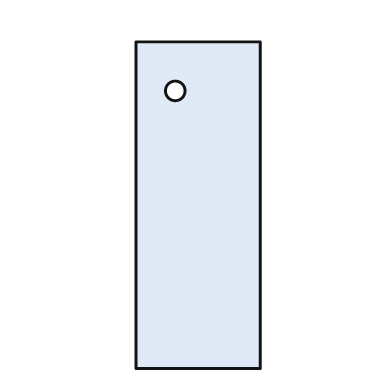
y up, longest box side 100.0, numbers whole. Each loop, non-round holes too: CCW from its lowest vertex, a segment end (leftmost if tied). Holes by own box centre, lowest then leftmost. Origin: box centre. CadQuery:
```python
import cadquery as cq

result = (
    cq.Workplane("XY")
    .moveTo(-19.0, -50.0)
    .lineTo(19.0, -50.0)
    .lineTo(19.0, 50.0)
    .lineTo(-19.0, 50.0)
    .close()
    .moveTo(-7.0, 35.0)
    .circle(3.0)
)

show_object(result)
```